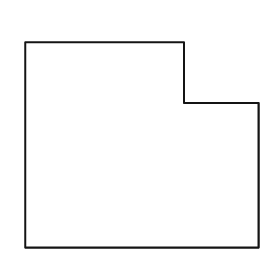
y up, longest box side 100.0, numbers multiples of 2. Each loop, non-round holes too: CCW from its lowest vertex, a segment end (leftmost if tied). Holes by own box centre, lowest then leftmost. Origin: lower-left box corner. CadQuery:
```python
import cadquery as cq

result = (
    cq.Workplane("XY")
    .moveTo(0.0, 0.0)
    .lineTo(100.0, 0.0)
    .lineTo(100.0, 62.0)
    .lineTo(68.0, 62.0)
    .lineTo(68.0, 88.0)
    .lineTo(0.0, 88.0)
    .close()
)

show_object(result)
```